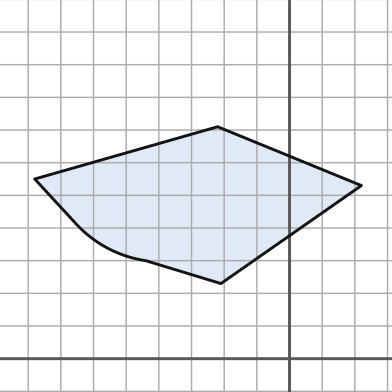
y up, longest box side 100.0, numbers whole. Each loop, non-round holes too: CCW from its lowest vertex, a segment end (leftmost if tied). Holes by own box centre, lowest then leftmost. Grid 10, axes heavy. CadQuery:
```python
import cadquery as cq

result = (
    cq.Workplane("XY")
    .moveTo(-21.0, 23.0)
    .lineTo(22.0, 53.0)
    .lineTo(-22.0, 71.0)
    .lineTo(-78.0, 55.0)
    .lineTo(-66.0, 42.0)
    .threePointArc((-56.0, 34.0), (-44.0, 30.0))
    .close()
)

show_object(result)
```